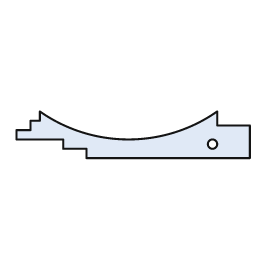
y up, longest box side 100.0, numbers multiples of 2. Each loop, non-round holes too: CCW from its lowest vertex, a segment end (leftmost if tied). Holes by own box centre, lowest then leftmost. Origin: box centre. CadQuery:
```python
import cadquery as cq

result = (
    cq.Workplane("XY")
    .moveTo(-20.0, -10.0)
    .lineTo(50.0, -10.0)
    .lineTo(50.0, 4.0)
    .lineTo(36.0, 4.0)
    .lineTo(36.0, 10.0)
    .threePointArc((-2.0, -2.0), (-40.0, 10.0))
    .lineTo(-40.0, 6.0)
    .lineTo(-44.0, 6.0)
    .lineTo(-44.0, 2.0)
    .lineTo(-50.0, 2.0)
    .lineTo(-50.0, -2.0)
    .lineTo(-30.0, -2.0)
    .lineTo(-30.0, -6.0)
    .lineTo(-20.0, -6.0)
    .close()
    .moveTo(34.0, -4.0)
    .circle(2.0)
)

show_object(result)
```